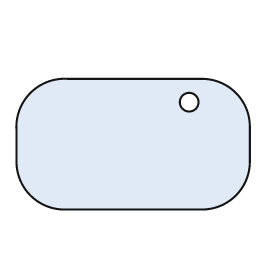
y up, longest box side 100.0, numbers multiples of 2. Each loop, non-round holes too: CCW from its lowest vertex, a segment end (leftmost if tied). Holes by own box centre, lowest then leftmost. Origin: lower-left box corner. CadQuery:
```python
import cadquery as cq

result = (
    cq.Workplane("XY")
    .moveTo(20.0, 0.0)
    .lineTo(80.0, 0.0)
    .threePointArc((94.0, 6.0), (100.0, 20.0))
    .lineTo(100.0, 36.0)
    .threePointArc((94.0, 50.0), (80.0, 56.0))
    .lineTo(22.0, 56.0)
    .threePointArc((6.0, 50.0), (0.0, 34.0))
    .lineTo(0.0, 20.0)
    .threePointArc((6.0, 6.0), (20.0, 0.0))
    .close()
    .moveTo(74.0, 46.0)
    .circle(4.0)
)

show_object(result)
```